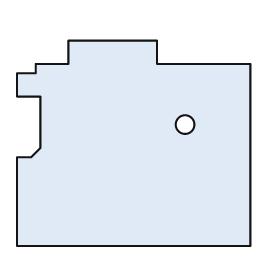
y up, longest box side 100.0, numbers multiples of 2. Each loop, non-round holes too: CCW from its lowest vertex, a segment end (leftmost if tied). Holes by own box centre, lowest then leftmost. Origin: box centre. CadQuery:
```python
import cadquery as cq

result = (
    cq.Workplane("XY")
    .moveTo(-50.0, -44.0)
    .lineTo(50.0, -44.0)
    .lineTo(50.0, 34.0)
    .lineTo(10.0, 34.0)
    .lineTo(10.0, 44.0)
    .lineTo(-28.0, 44.0)
    .lineTo(-28.0, 34.0)
    .lineTo(-42.0, 34.0)
    .lineTo(-42.0, 30.0)
    .lineTo(-50.0, 30.0)
    .lineTo(-50.0, 20.0)
    .lineTo(-40.0, 20.0)
    .lineTo(-40.0, -2.0)
    .lineTo(-44.0, -6.0)
    .lineTo(-50.0, -6.0)
    .close()
    .moveTo(22.0, 8.0)
    .circle(4.0)
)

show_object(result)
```